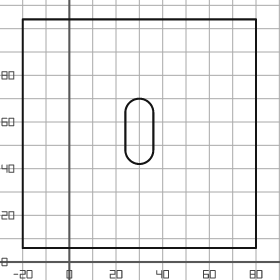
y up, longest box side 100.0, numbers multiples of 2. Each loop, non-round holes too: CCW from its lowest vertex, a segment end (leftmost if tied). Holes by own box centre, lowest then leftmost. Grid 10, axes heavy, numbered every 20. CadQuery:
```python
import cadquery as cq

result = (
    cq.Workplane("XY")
    .moveTo(-20.0, 6.0)
    .lineTo(80.0, 6.0)
    .lineTo(80.0, 104.0)
    .lineTo(-20.0, 104.0)
    .close()
    .moveTo(24.0, 48.0)
    .threePointArc((30.0, 42.0), (36.0, 48.0))
    .lineTo(36.0, 64.0)
    .threePointArc((30.0, 70.0), (24.0, 64.0))
    .close()
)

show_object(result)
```